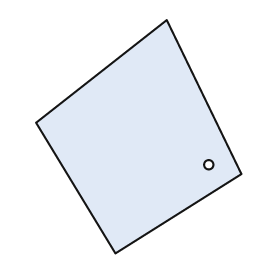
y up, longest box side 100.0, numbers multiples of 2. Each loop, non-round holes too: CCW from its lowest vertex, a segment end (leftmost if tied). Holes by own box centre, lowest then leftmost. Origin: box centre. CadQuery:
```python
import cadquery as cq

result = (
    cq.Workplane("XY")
    .moveTo(-10.0, -50.0)
    .lineTo(44.0, -16.0)
    .lineTo(12.0, 50.0)
    .lineTo(-44.0, 6.0)
    .close()
    .moveTo(30.0, -12.0)
    .circle(2.0)
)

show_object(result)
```